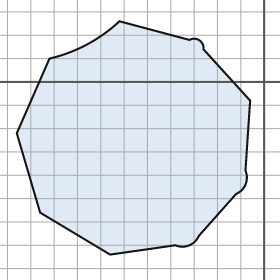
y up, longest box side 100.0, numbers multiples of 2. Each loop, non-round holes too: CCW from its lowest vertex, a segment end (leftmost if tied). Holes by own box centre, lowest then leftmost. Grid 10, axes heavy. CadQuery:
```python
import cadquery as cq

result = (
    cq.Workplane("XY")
    .moveTo(-66.0, -74.0)
    .lineTo(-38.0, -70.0)
    .threePointArc((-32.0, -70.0), (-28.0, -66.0))
    .lineTo(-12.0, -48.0)
    .threePointArc((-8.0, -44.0), (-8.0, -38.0))
    .lineTo(-6.0, -8.0)
    .lineTo(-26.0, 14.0)
    .threePointArc((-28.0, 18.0), (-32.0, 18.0))
    .lineTo(-62.0, 26.0)
    .threePointArc((-76.0, 16.0), (-92.0, 10.0))
    .lineTo(-106.0, -22.0)
    .lineTo(-96.0, -56.0)
    .close()
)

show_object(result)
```